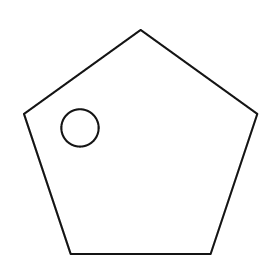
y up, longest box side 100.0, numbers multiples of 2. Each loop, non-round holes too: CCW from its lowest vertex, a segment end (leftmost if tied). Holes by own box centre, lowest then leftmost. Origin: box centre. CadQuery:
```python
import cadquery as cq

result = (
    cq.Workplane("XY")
    .moveTo(-30.0, -48.0)
    .lineTo(30.0, -48.0)
    .lineTo(50.0, 12.0)
    .lineTo(0.0, 48.0)
    .lineTo(-50.0, 12.0)
    .close()
    .moveTo(-26.0, 6.0)
    .circle(8.0)
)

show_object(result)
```